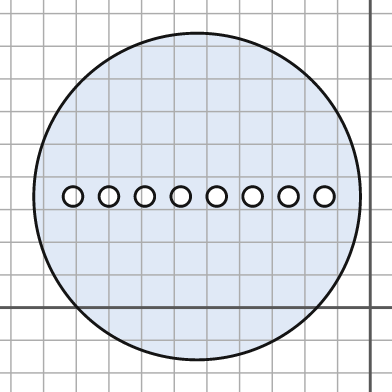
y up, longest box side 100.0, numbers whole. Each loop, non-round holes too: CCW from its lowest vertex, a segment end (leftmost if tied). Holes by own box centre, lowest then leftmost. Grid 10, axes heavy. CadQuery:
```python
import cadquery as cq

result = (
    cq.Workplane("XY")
    .moveTo(-53.0, 34.0)
    .circle(50.0)
    .moveTo(-91.0, 34.0)
    .circle(3.0)
    .moveTo(-80.0, 34.0)
    .circle(3.0)
    .moveTo(-69.0, 34.0)
    .circle(3.0)
    .moveTo(-58.0, 34.0)
    .circle(3.0)
    .moveTo(-47.0, 34.0)
    .circle(3.0)
    .moveTo(-36.0, 34.0)
    .circle(3.0)
    .moveTo(-25.0, 34.0)
    .circle(3.0)
    .moveTo(-14.0, 34.0)
    .circle(3.0)
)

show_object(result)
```